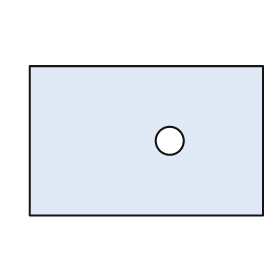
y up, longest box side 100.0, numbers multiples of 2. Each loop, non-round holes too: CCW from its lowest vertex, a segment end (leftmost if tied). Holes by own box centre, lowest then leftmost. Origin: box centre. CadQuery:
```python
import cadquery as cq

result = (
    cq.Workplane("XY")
    .moveTo(-50.0, -32.0)
    .lineTo(50.0, -32.0)
    .lineTo(50.0, 32.0)
    .lineTo(-50.0, 32.0)
    .close()
    .moveTo(10.0, 0.0)
    .circle(6.0)
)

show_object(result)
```